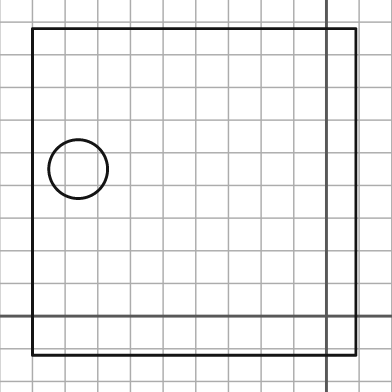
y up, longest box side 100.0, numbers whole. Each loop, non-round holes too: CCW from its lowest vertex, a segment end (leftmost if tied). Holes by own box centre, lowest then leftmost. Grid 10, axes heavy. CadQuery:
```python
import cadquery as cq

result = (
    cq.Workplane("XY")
    .moveTo(-90.0, -12.0)
    .lineTo(9.0, -12.0)
    .lineTo(9.0, 88.0)
    .lineTo(-90.0, 88.0)
    .close()
    .moveTo(-76.0, 45.0)
    .circle(9.0)
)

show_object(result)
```